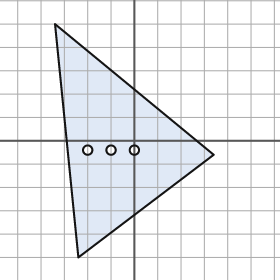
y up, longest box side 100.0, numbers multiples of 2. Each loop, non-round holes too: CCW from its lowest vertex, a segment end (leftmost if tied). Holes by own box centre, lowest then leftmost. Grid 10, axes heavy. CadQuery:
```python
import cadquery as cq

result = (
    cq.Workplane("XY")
    .moveTo(-24.0, -50.0)
    .lineTo(34.0, -6.0)
    .lineTo(-34.0, 50.0)
    .close()
    .moveTo(-20.0, -4.0)
    .circle(2.0)
    .moveTo(-10.0, -4.0)
    .circle(2.0)
    .moveTo(0.0, -4.0)
    .circle(2.0)
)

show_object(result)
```